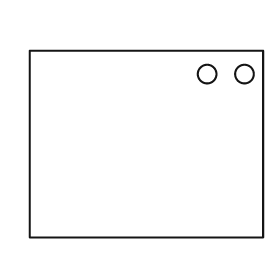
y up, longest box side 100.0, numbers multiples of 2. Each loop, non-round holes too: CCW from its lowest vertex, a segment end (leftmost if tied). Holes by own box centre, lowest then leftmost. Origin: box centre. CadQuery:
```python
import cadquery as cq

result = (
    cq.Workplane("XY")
    .moveTo(-50.0, -40.0)
    .lineTo(50.0, -40.0)
    .lineTo(50.0, 40.0)
    .lineTo(-50.0, 40.0)
    .close()
    .moveTo(26.0, 30.0)
    .circle(4.0)
    .moveTo(42.0, 30.0)
    .circle(4.0)
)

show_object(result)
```